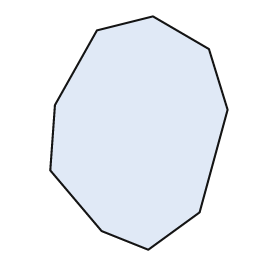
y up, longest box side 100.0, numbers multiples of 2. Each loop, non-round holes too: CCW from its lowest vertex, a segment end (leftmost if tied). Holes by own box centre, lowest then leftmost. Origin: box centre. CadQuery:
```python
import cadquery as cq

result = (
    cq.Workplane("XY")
    .moveTo(4.0, -50.0)
    .lineTo(26.0, -34.0)
    .lineTo(38.0, 10.0)
    .lineTo(30.0, 36.0)
    .lineTo(6.0, 50.0)
    .lineTo(-18.0, 44.0)
    .lineTo(-36.0, 12.0)
    .lineTo(-38.0, -16.0)
    .lineTo(-16.0, -42.0)
    .close()
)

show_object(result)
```